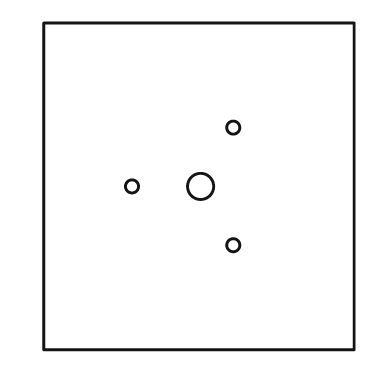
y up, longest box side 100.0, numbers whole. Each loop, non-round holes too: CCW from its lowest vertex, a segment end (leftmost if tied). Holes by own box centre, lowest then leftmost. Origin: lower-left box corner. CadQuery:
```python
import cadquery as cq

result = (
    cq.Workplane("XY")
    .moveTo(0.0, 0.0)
    .lineTo(95.0, 0.0)
    .lineTo(95.0, 100.0)
    .lineTo(0.0, 100.0)
    .close()
    .moveTo(58.0, 32.0)
    .circle(2.0)
    .moveTo(27.0, 50.0)
    .circle(2.0)
    .moveTo(48.0, 50.0)
    .circle(4.0)
    .moveTo(58.0, 68.0)
    .circle(2.0)
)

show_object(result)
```